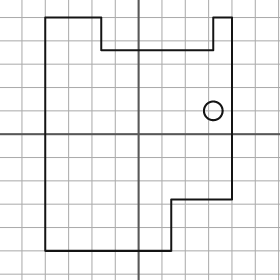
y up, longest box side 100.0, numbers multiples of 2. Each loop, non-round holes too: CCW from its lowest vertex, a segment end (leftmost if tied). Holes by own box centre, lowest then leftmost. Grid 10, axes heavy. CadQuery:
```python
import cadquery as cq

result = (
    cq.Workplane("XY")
    .moveTo(-40.0, -50.0)
    .lineTo(14.0, -50.0)
    .lineTo(14.0, -28.0)
    .lineTo(40.0, -28.0)
    .lineTo(40.0, 50.0)
    .lineTo(32.0, 50.0)
    .lineTo(32.0, 36.0)
    .lineTo(-16.0, 36.0)
    .lineTo(-16.0, 50.0)
    .lineTo(-40.0, 50.0)
    .close()
    .moveTo(32.0, 10.0)
    .circle(4.0)
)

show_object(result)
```